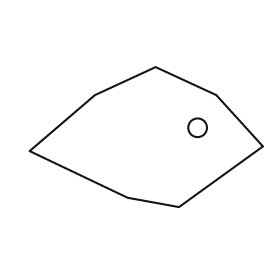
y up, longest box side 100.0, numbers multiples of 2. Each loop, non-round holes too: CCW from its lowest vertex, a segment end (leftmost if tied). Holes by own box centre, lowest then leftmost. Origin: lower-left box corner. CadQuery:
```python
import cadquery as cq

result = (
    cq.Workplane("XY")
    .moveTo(64.0, 0.0)
    .lineTo(100.0, 26.0)
    .lineTo(80.0, 48.0)
    .lineTo(54.0, 60.0)
    .lineTo(28.0, 48.0)
    .lineTo(0.0, 24.0)
    .lineTo(42.0, 4.0)
    .close()
    .moveTo(72.0, 34.0)
    .circle(4.0)
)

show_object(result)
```